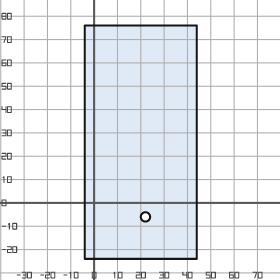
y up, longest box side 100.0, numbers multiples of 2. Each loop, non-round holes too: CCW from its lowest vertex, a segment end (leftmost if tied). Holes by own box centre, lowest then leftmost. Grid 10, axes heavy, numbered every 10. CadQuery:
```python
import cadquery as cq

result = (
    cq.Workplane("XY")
    .moveTo(-4.0, -24.0)
    .lineTo(44.0, -24.0)
    .lineTo(44.0, 76.0)
    .lineTo(-4.0, 76.0)
    .close()
    .moveTo(22.0, -6.0)
    .circle(2.0)
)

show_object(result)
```